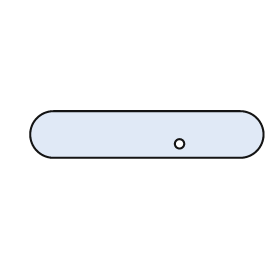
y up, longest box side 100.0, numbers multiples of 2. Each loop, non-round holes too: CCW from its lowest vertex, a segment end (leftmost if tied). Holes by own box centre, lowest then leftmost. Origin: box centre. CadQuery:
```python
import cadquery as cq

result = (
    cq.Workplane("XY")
    .moveTo(-40.0, -10.0)
    .lineTo(40.0, -10.0)
    .threePointArc((50.0, 0.0), (40.0, 10.0))
    .lineTo(-40.0, 10.0)
    .threePointArc((-50.0, 0.0), (-40.0, -10.0))
    .close()
    .moveTo(14.0, -4.0)
    .circle(2.0)
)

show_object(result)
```